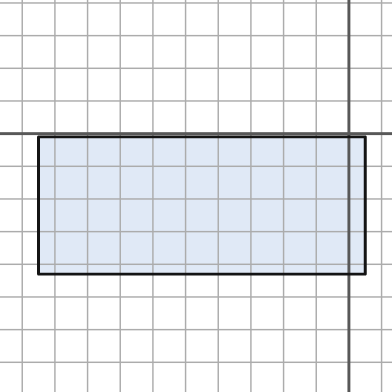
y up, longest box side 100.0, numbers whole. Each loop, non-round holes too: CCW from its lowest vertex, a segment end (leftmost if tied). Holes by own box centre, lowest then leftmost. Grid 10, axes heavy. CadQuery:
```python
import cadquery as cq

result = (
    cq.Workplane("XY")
    .moveTo(-95.0, -43.0)
    .lineTo(5.0, -43.0)
    .lineTo(5.0, -1.0)
    .lineTo(-95.0, -1.0)
    .close()
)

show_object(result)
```